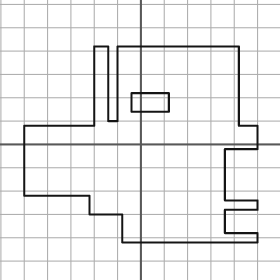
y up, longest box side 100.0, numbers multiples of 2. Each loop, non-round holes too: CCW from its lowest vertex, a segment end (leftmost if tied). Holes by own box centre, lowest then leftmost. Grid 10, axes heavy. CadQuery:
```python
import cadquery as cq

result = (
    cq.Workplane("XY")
    .moveTo(-8.0, -42.0)
    .lineTo(50.0, -42.0)
    .lineTo(50.0, -38.0)
    .lineTo(36.0, -38.0)
    .lineTo(36.0, -28.0)
    .lineTo(50.0, -28.0)
    .lineTo(50.0, -24.0)
    .lineTo(36.0, -24.0)
    .lineTo(36.0, -2.0)
    .lineTo(50.0, -2.0)
    .lineTo(50.0, 8.0)
    .lineTo(42.0, 8.0)
    .lineTo(42.0, 42.0)
    .lineTo(-10.0, 42.0)
    .lineTo(-10.0, 10.0)
    .lineTo(-14.0, 10.0)
    .lineTo(-14.0, 42.0)
    .lineTo(-20.0, 42.0)
    .lineTo(-20.0, 8.0)
    .lineTo(-50.0, 8.0)
    .lineTo(-50.0, -22.0)
    .lineTo(-22.0, -22.0)
    .lineTo(-22.0, -30.0)
    .lineTo(-8.0, -30.0)
    .close()
    .moveTo(-4.0, 14.0)
    .lineTo(12.0, 14.0)
    .lineTo(12.0, 22.0)
    .lineTo(-4.0, 22.0)
    .close()
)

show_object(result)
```